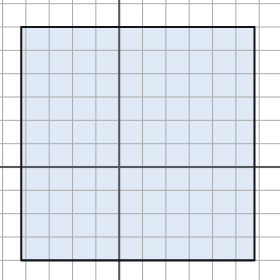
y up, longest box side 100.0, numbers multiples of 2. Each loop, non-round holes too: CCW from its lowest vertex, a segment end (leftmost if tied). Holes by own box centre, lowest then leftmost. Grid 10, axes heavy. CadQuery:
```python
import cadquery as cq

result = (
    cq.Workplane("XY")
    .moveTo(-42.0, -40.0)
    .lineTo(58.0, -40.0)
    .lineTo(58.0, 60.0)
    .lineTo(-42.0, 60.0)
    .close()
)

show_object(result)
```